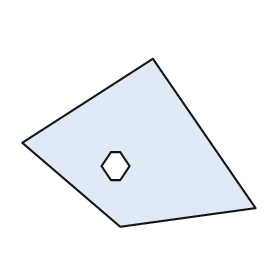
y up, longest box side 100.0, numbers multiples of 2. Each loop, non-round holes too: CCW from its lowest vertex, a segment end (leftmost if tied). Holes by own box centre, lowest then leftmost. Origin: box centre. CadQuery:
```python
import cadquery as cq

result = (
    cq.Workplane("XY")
    .moveTo(-8.0, -36.0)
    .lineTo(50.0, -28.0)
    .lineTo(6.0, 36.0)
    .lineTo(-50.0, 0.0)
    .close()
    .moveTo(-12.0, -16.0)
    .lineTo(-8.0, -16.0)
    .lineTo(-4.0, -10.0)
    .lineTo(-8.0, -4.0)
    .lineTo(-12.0, -4.0)
    .lineTo(-16.0, -10.0)
    .close()
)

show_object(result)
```